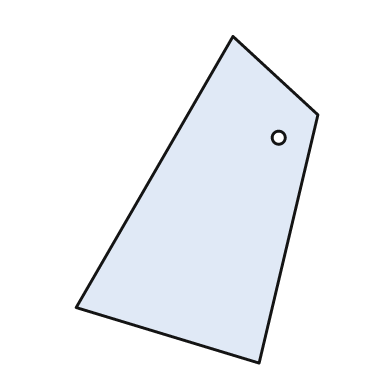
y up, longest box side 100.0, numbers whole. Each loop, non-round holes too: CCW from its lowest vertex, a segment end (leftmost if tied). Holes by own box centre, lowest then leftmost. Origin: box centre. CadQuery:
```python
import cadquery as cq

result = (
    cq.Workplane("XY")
    .moveTo(19.0, -50.0)
    .lineTo(37.0, 26.0)
    .lineTo(11.0, 50.0)
    .lineTo(-37.0, -33.0)
    .close()
    .moveTo(25.0, 19.0)
    .circle(2.0)
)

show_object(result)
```